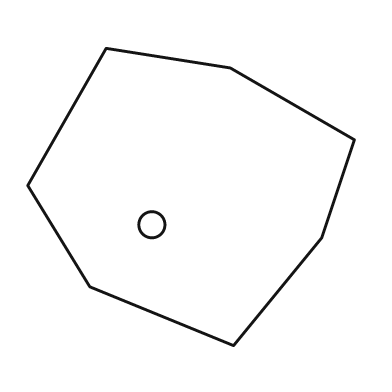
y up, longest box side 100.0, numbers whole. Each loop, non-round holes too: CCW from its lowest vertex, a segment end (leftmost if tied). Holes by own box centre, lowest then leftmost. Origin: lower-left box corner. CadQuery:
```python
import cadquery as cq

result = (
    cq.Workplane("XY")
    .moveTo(63.0, 0.0)
    .lineTo(90.0, 33.0)
    .lineTo(100.0, 63.0)
    .lineTo(62.0, 85.0)
    .lineTo(24.0, 91.0)
    .lineTo(0.0, 49.0)
    .lineTo(19.0, 18.0)
    .close()
    .moveTo(38.0, 37.0)
    .circle(4.0)
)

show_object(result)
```